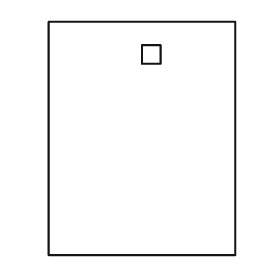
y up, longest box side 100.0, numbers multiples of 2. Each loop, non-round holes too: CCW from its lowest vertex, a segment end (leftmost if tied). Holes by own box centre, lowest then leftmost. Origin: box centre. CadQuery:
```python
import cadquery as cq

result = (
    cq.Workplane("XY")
    .moveTo(-40.0, -50.0)
    .lineTo(40.0, -50.0)
    .lineTo(40.0, 50.0)
    .lineTo(-40.0, 50.0)
    .close()
    .moveTo(0.0, 32.0)
    .lineTo(8.0, 32.0)
    .lineTo(8.0, 40.0)
    .lineTo(0.0, 40.0)
    .close()
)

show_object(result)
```